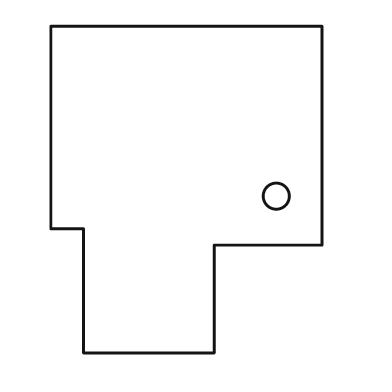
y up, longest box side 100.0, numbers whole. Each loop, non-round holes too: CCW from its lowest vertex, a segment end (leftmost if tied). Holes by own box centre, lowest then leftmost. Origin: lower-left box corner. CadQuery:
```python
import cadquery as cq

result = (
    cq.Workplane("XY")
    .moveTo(10.0, 0.0)
    .lineTo(50.0, 0.0)
    .lineTo(50.0, 33.0)
    .lineTo(83.0, 33.0)
    .lineTo(83.0, 100.0)
    .lineTo(0.0, 100.0)
    .lineTo(0.0, 38.0)
    .lineTo(10.0, 38.0)
    .close()
    .moveTo(69.0, 48.0)
    .circle(4.0)
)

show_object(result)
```